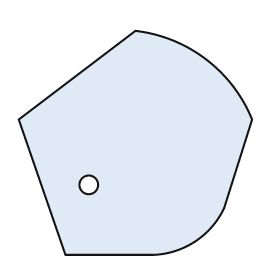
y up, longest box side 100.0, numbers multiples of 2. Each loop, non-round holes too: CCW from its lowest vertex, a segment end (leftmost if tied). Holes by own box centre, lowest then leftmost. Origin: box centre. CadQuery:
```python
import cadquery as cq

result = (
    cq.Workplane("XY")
    .moveTo(-30.0, -48.0)
    .lineTo(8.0, -48.0)
    .threePointArc((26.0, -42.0), (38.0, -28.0))
    .lineTo(50.0, 10.0)
    .threePointArc((30.0, 36.0), (0.0, 48.0))
    .lineTo(-50.0, 10.0)
    .close()
    .moveTo(-20.0, -18.0)
    .circle(4.0)
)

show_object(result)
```